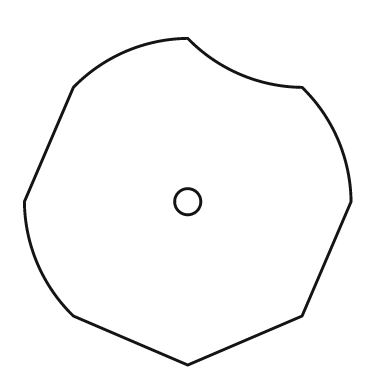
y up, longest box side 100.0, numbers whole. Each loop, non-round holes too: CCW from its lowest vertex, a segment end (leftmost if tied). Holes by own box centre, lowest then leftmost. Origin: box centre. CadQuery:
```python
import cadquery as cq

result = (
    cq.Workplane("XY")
    .moveTo(0.0, -50.0)
    .lineTo(35.0, -35.0)
    .lineTo(50.0, 0.0)
    .threePointArc((46.0, 19.0), (35.0, 35.0))
    .threePointArc((16.0, 39.0), (0.0, 50.0))
    .threePointArc((-19.0, 46.0), (-35.0, 35.0))
    .lineTo(-50.0, 0.0)
    .threePointArc((-46.0, -19.0), (-35.0, -35.0))
    .close()
    .moveTo(0.0, 0.0)
    .circle(4.0)
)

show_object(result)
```